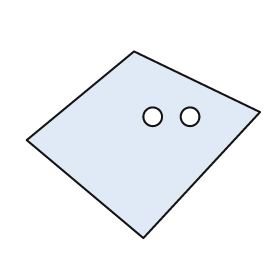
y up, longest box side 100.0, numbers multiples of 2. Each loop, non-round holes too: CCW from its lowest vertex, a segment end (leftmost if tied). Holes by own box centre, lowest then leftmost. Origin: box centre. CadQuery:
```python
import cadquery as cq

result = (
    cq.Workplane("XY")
    .moveTo(0.0, -40.0)
    .lineTo(50.0, 14.0)
    .lineTo(-4.0, 40.0)
    .lineTo(-50.0, 2.0)
    .close()
    .moveTo(4.0, 12.0)
    .circle(4.0)
    .moveTo(20.0, 12.0)
    .circle(4.0)
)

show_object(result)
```